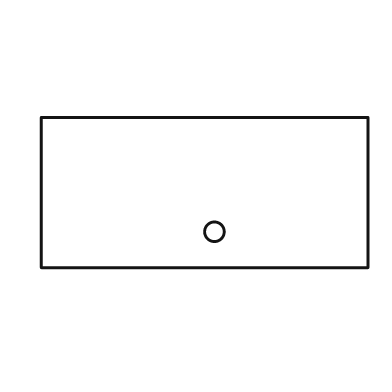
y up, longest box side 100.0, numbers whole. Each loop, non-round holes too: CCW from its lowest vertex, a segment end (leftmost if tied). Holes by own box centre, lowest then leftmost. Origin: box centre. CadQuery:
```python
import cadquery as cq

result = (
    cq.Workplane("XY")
    .moveTo(-50.0, -23.0)
    .lineTo(50.0, -23.0)
    .lineTo(50.0, 23.0)
    .lineTo(-50.0, 23.0)
    .close()
    .moveTo(3.0, -12.0)
    .circle(3.0)
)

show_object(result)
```